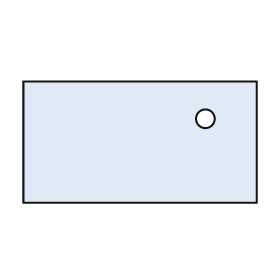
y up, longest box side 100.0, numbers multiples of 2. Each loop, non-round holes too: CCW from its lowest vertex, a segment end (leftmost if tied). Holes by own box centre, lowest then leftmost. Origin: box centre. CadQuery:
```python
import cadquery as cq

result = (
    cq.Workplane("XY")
    .moveTo(-50.0, -26.0)
    .lineTo(50.0, -26.0)
    .lineTo(50.0, 26.0)
    .lineTo(-50.0, 26.0)
    .close()
    .moveTo(28.0, 10.0)
    .circle(4.0)
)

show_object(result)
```